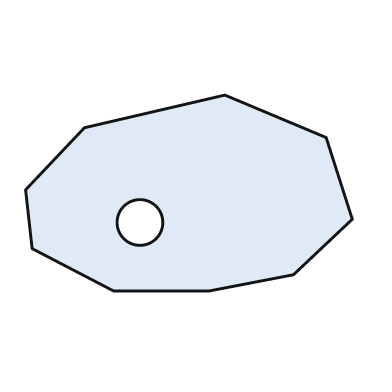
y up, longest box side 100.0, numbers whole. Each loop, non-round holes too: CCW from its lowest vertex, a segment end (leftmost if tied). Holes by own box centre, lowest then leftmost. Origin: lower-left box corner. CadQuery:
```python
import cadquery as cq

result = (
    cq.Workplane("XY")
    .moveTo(27.0, 0.0)
    .lineTo(56.0, 0.0)
    .lineTo(82.0, 5.0)
    .lineTo(100.0, 22.0)
    .lineTo(92.0, 47.0)
    .lineTo(61.0, 60.0)
    .lineTo(18.0, 50.0)
    .lineTo(0.0, 31.0)
    .lineTo(2.0, 13.0)
    .close()
    .moveTo(35.0, 21.0)
    .circle(7.0)
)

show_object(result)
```